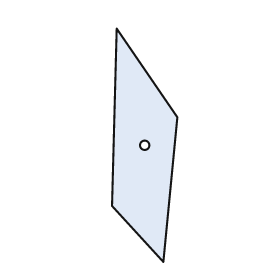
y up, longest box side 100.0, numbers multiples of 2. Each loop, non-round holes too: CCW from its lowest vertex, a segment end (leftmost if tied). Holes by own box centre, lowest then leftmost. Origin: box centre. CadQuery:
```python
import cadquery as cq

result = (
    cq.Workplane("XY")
    .moveTo(8.0, -50.0)
    .lineTo(14.0, 12.0)
    .lineTo(-12.0, 50.0)
    .lineTo(-14.0, -26.0)
    .close()
    .moveTo(0.0, 0.0)
    .circle(2.0)
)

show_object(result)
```